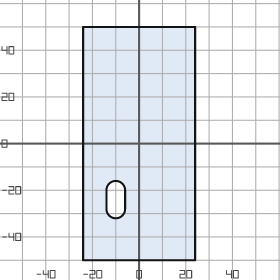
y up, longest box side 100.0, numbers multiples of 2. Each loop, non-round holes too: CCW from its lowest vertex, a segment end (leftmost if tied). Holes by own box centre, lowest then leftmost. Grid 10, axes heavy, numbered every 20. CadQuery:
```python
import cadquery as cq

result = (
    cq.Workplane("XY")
    .moveTo(-24.0, -50.0)
    .lineTo(24.0, -50.0)
    .lineTo(24.0, 50.0)
    .lineTo(-24.0, 50.0)
    .close()
    .moveTo(-14.0, -28.0)
    .threePointArc((-10.0, -32.0), (-6.0, -28.0))
    .lineTo(-6.0, -20.0)
    .threePointArc((-10.0, -16.0), (-14.0, -20.0))
    .close()
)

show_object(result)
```